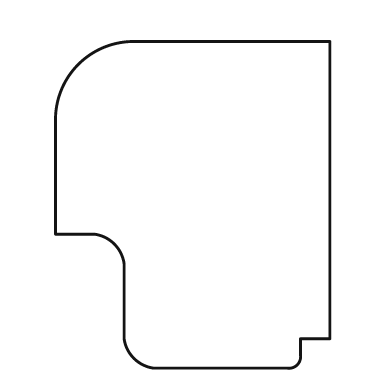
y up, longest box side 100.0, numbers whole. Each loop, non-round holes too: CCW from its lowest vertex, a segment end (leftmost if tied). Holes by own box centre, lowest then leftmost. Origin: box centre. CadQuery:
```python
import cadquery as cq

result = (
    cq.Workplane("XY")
    .moveTo(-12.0, -50.0)
    .lineTo(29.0, -50.0)
    .threePointArc((32.0, -49.0), (33.0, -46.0))
    .lineTo(33.0, -41.0)
    .lineTo(42.0, -41.0)
    .lineTo(42.0, 50.0)
    .lineTo(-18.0, 50.0)
    .threePointArc((-35.0, 43.0), (-42.0, 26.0))
    .lineTo(-42.0, -9.0)
    .lineTo(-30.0, -9.0)
    .threePointArc((-24.0, -12.0), (-21.0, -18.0))
    .lineTo(-21.0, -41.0)
    .threePointArc((-18.0, -47.0), (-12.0, -50.0))
    .close()
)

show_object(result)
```